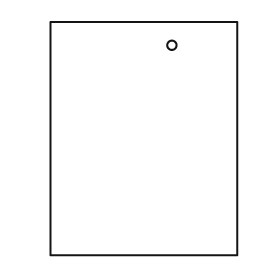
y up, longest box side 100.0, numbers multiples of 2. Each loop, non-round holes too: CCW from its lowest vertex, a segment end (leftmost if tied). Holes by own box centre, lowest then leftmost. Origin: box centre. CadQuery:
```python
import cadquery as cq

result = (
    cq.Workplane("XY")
    .moveTo(-40.0, -50.0)
    .lineTo(40.0, -50.0)
    .lineTo(40.0, 50.0)
    .lineTo(-40.0, 50.0)
    .close()
    .moveTo(12.0, 40.0)
    .circle(2.0)
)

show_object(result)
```